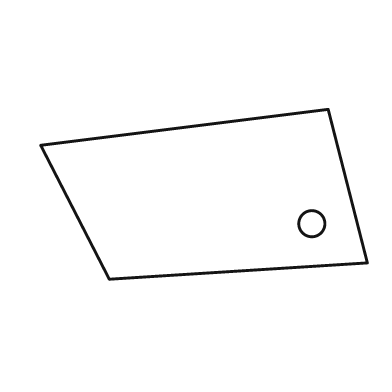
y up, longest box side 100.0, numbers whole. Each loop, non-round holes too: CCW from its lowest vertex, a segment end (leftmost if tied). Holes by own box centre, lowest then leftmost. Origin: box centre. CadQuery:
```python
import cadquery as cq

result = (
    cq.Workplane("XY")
    .moveTo(-29.0, -26.0)
    .lineTo(50.0, -21.0)
    .lineTo(38.0, 26.0)
    .lineTo(-50.0, 15.0)
    .close()
    .moveTo(33.0, -9.0)
    .circle(4.0)
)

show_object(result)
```